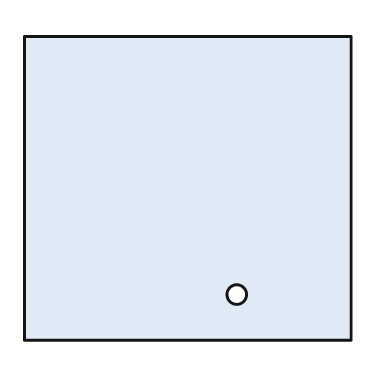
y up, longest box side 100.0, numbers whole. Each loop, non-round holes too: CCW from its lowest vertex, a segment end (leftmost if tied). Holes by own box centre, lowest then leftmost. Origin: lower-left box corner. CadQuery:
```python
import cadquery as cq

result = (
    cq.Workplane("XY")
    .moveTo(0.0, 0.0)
    .lineTo(100.0, 0.0)
    .lineTo(100.0, 93.0)
    .lineTo(0.0, 93.0)
    .close()
    .moveTo(65.0, 14.0)
    .circle(3.0)
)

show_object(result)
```